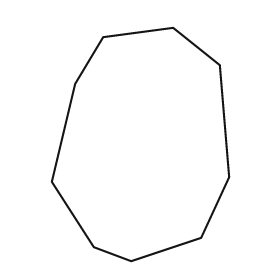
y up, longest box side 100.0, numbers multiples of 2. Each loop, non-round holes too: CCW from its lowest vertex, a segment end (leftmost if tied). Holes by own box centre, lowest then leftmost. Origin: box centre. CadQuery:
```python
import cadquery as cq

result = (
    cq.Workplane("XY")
    .moveTo(-4.0, -50.0)
    .lineTo(26.0, -40.0)
    .lineTo(38.0, -14.0)
    .lineTo(34.0, 34.0)
    .lineTo(14.0, 50.0)
    .lineTo(-16.0, 46.0)
    .lineTo(-28.0, 26.0)
    .lineTo(-38.0, -16.0)
    .lineTo(-20.0, -44.0)
    .close()
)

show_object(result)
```